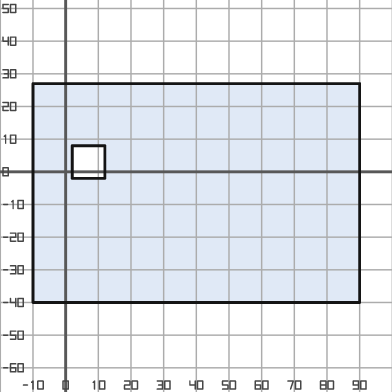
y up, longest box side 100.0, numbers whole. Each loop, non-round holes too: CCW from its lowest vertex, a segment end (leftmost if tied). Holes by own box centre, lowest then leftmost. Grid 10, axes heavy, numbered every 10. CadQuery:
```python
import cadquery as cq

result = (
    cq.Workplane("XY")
    .moveTo(-10.0, -40.0)
    .lineTo(90.0, -40.0)
    .lineTo(90.0, 27.0)
    .lineTo(-10.0, 27.0)
    .close()
    .moveTo(2.0, -2.0)
    .lineTo(12.0, -2.0)
    .lineTo(12.0, 8.0)
    .lineTo(2.0, 8.0)
    .close()
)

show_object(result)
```